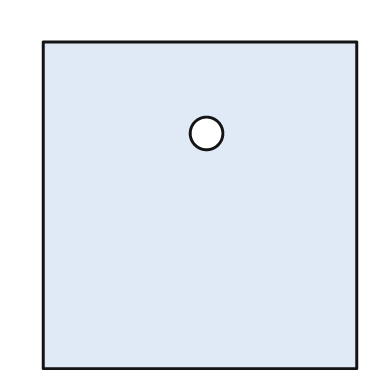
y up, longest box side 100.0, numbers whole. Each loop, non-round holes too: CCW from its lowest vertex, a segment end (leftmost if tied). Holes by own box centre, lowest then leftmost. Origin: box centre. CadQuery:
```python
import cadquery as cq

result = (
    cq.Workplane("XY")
    .moveTo(-48.0, -50.0)
    .lineTo(48.0, -50.0)
    .lineTo(48.0, 50.0)
    .lineTo(-48.0, 50.0)
    .close()
    .moveTo(2.0, 22.0)
    .circle(5.0)
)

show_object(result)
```